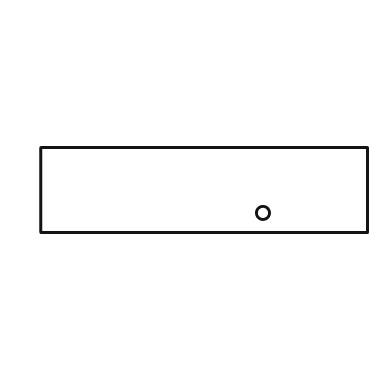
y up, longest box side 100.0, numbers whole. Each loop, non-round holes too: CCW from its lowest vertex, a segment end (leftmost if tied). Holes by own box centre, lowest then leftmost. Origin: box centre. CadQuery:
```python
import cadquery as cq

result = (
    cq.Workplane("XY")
    .moveTo(-50.0, -13.0)
    .lineTo(50.0, -13.0)
    .lineTo(50.0, 13.0)
    .lineTo(-50.0, 13.0)
    .close()
    .moveTo(18.0, -7.0)
    .circle(2.0)
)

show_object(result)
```